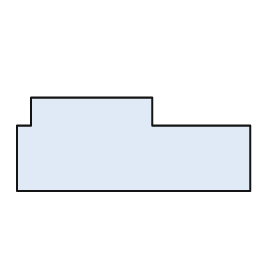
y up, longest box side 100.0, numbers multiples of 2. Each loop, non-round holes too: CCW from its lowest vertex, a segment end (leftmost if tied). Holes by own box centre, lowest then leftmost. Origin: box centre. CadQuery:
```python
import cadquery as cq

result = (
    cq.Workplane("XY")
    .moveTo(-50.0, -20.0)
    .lineTo(50.0, -20.0)
    .lineTo(50.0, 8.0)
    .lineTo(8.0, 8.0)
    .lineTo(8.0, 20.0)
    .lineTo(-44.0, 20.0)
    .lineTo(-44.0, 8.0)
    .lineTo(-50.0, 8.0)
    .close()
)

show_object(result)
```